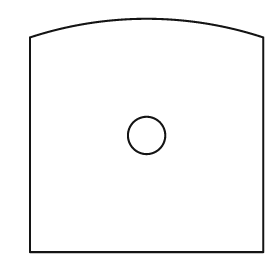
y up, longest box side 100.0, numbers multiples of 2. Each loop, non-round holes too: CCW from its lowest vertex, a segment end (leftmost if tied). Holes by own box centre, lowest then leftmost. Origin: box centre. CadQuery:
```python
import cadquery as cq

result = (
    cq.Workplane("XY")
    .moveTo(-50.0, -50.0)
    .lineTo(50.0, -50.0)
    .lineTo(50.0, 42.0)
    .threePointArc((0.0, 50.0), (-50.0, 42.0))
    .close()
    .moveTo(0.0, 0.0)
    .circle(8.0)
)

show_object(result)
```